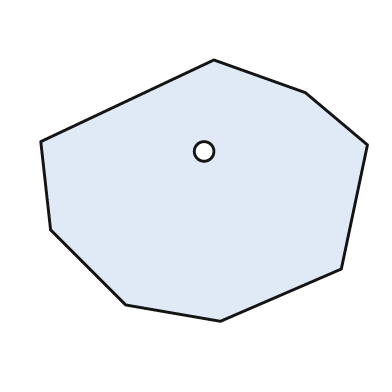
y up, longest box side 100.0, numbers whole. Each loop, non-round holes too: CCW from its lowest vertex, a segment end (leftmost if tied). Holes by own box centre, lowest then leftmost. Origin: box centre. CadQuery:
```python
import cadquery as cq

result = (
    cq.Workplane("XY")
    .moveTo(5.0, -40.0)
    .lineTo(42.0, -24.0)
    .lineTo(50.0, 14.0)
    .lineTo(31.0, 30.0)
    .lineTo(3.0, 40.0)
    .lineTo(-50.0, 15.0)
    .lineTo(-47.0, -12.0)
    .lineTo(-24.0, -35.0)
    .close()
    .moveTo(0.0, 12.0)
    .circle(3.0)
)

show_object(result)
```